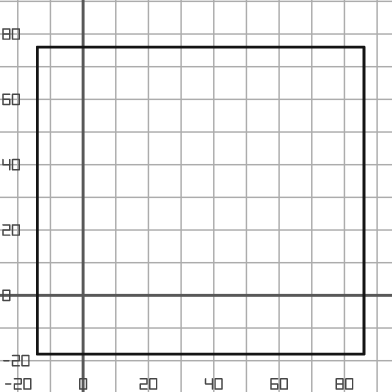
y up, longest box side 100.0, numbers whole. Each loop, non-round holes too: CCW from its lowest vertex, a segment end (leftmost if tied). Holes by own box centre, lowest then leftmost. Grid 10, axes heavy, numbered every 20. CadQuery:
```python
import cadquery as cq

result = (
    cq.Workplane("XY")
    .moveTo(-14.0, -18.0)
    .lineTo(86.0, -18.0)
    .lineTo(86.0, 76.0)
    .lineTo(-14.0, 76.0)
    .close()
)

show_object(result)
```